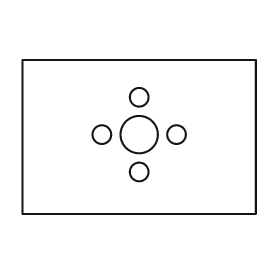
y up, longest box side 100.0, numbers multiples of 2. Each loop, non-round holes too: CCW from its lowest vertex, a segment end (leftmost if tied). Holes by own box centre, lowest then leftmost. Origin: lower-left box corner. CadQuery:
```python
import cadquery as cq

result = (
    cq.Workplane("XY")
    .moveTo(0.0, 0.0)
    .lineTo(100.0, 0.0)
    .lineTo(100.0, 66.0)
    .lineTo(0.0, 66.0)
    .close()
    .moveTo(50.0, 18.0)
    .circle(4.0)
    .moveTo(34.0, 34.0)
    .circle(4.0)
    .moveTo(50.0, 34.0)
    .circle(8.0)
    .moveTo(66.0, 34.0)
    .circle(4.0)
    .moveTo(50.0, 50.0)
    .circle(4.0)
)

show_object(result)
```